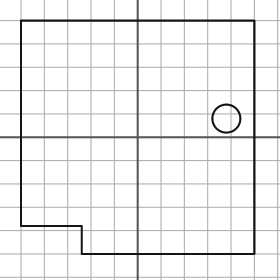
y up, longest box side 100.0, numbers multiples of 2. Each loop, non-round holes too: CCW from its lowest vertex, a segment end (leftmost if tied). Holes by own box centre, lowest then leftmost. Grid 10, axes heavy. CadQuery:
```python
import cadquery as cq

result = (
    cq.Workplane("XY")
    .moveTo(-24.0, -50.0)
    .lineTo(50.0, -50.0)
    .lineTo(50.0, 50.0)
    .lineTo(-50.0, 50.0)
    .lineTo(-50.0, -38.0)
    .lineTo(-24.0, -38.0)
    .close()
    .moveTo(38.0, 8.0)
    .circle(6.0)
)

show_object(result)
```